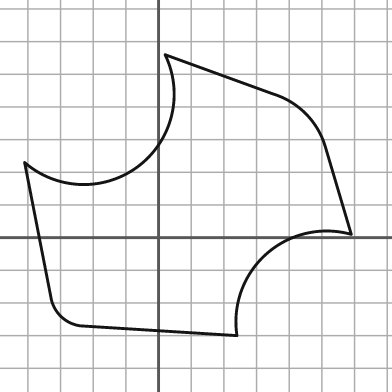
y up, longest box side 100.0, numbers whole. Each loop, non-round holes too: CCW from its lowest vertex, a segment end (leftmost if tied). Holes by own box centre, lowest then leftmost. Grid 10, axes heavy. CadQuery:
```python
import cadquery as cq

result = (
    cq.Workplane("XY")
    .moveTo(24.0, -30.0)
    .threePointArc((33.0, -5.0), (59.0, 1.0))
    .lineTo(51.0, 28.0)
    .threePointArc((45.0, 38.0), (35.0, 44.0))
    .lineTo(2.0, 56.0)
    .threePointArc((-6.0, 22.0), (-41.0, 23.0))
    .lineTo(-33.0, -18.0)
    .threePointArc((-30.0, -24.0), (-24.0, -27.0))
    .close()
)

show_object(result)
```